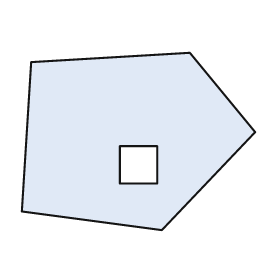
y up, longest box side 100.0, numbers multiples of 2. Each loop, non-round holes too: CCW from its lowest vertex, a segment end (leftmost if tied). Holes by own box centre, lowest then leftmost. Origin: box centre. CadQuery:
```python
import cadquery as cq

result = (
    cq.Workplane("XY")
    .moveTo(10.0, -38.0)
    .lineTo(50.0, 4.0)
    .lineTo(22.0, 38.0)
    .lineTo(-46.0, 34.0)
    .lineTo(-50.0, -30.0)
    .close()
    .moveTo(-8.0, -18.0)
    .lineTo(8.0, -18.0)
    .lineTo(8.0, -2.0)
    .lineTo(-8.0, -2.0)
    .close()
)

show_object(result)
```